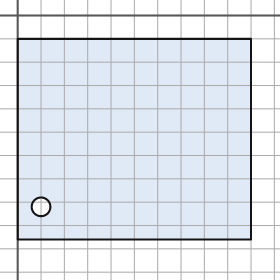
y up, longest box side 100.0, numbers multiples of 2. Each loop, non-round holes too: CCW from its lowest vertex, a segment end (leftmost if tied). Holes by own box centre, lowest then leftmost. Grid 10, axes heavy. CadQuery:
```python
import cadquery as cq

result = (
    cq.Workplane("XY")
    .moveTo(0.0, -96.0)
    .lineTo(100.0, -96.0)
    .lineTo(100.0, -10.0)
    .lineTo(0.0, -10.0)
    .close()
    .moveTo(10.0, -82.0)
    .circle(4.0)
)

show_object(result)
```